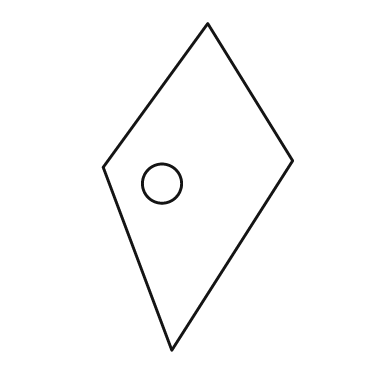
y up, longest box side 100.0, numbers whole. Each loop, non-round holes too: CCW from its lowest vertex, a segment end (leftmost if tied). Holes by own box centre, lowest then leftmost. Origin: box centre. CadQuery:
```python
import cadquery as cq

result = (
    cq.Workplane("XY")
    .moveTo(-8.0, -50.0)
    .lineTo(29.0, 8.0)
    .lineTo(3.0, 50.0)
    .lineTo(-29.0, 6.0)
    .close()
    .moveTo(-11.0, 1.0)
    .circle(6.0)
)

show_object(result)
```